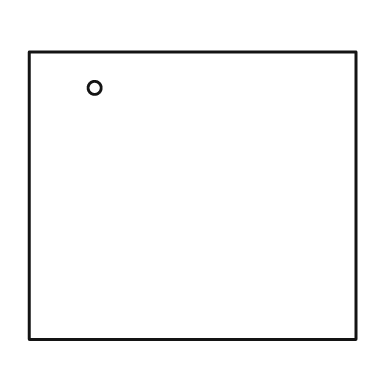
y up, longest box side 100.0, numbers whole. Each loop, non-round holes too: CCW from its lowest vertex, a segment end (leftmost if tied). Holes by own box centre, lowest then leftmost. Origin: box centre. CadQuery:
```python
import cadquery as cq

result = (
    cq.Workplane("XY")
    .moveTo(-50.0, -44.0)
    .lineTo(50.0, -44.0)
    .lineTo(50.0, 44.0)
    .lineTo(-50.0, 44.0)
    .close()
    .moveTo(-30.0, 33.0)
    .circle(2.0)
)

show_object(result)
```